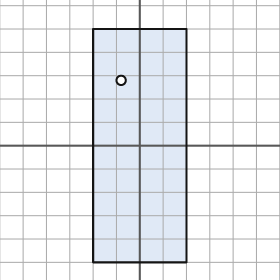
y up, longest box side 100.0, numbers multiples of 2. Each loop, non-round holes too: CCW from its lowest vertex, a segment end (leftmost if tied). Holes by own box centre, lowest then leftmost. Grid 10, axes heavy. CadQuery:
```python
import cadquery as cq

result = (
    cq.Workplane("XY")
    .moveTo(-20.0, -50.0)
    .lineTo(20.0, -50.0)
    .lineTo(20.0, 50.0)
    .lineTo(-20.0, 50.0)
    .close()
    .moveTo(-8.0, 28.0)
    .circle(2.0)
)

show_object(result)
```